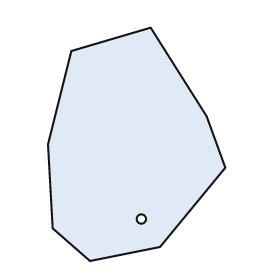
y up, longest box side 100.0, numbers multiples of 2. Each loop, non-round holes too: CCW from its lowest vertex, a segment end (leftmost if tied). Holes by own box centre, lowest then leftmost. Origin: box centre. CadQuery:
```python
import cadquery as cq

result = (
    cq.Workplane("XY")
    .moveTo(-20.0, -50.0)
    .lineTo(10.0, -44.0)
    .lineTo(38.0, -10.0)
    .lineTo(30.0, 12.0)
    .lineTo(6.0, 50.0)
    .lineTo(-28.0, 40.0)
    .lineTo(-38.0, 0.0)
    .lineTo(-36.0, -36.0)
    .close()
    .moveTo(2.0, -32.0)
    .circle(2.0)
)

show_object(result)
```